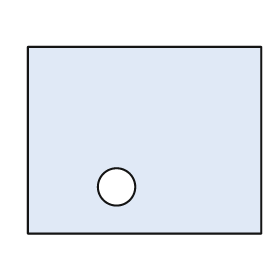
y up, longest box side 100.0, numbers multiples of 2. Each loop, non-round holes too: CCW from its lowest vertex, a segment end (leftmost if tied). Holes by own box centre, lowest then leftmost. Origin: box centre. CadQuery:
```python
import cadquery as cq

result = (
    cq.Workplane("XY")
    .moveTo(-50.0, -40.0)
    .lineTo(50.0, -40.0)
    .lineTo(50.0, 40.0)
    .lineTo(-50.0, 40.0)
    .close()
    .moveTo(-12.0, -20.0)
    .circle(8.0)
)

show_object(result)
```